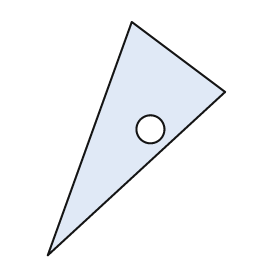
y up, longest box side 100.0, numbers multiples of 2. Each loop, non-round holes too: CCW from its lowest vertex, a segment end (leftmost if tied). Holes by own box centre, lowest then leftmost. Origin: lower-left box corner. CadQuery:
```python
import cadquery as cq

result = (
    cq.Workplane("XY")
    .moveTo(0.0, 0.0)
    .lineTo(76.0, 70.0)
    .lineTo(36.0, 100.0)
    .close()
    .moveTo(44.0, 54.0)
    .circle(6.0)
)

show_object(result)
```